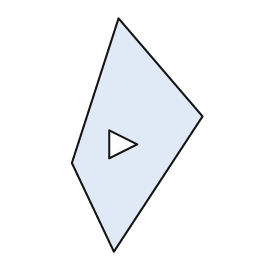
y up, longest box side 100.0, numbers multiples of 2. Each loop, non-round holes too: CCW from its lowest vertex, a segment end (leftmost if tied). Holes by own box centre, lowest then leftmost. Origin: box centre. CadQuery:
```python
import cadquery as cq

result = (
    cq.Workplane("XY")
    .moveTo(-10.0, -50.0)
    .lineTo(28.0, 8.0)
    .lineTo(-8.0, 50.0)
    .lineTo(-28.0, -12.0)
    .close()
    .moveTo(-12.0, -10.0)
    .lineTo(0.0, -4.0)
    .lineTo(-12.0, 2.0)
    .close()
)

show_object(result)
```